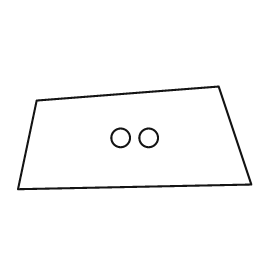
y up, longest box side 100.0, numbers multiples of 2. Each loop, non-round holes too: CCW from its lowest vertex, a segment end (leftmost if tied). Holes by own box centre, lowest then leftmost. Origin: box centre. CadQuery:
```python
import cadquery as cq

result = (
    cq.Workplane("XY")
    .moveTo(-50.0, -22.0)
    .lineTo(50.0, -20.0)
    .lineTo(36.0, 22.0)
    .lineTo(-42.0, 16.0)
    .close()
    .moveTo(-6.0, 0.0)
    .circle(4.0)
    .moveTo(6.0, 0.0)
    .circle(4.0)
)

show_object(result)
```